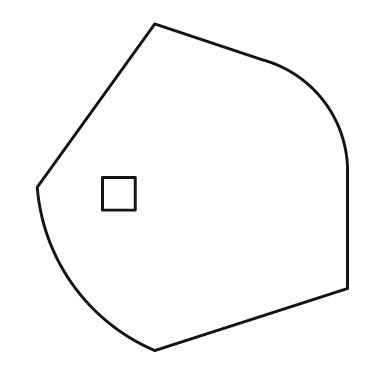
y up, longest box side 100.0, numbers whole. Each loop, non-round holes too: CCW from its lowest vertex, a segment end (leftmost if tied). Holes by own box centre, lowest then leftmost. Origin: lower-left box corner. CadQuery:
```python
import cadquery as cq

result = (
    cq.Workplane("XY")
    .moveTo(36.0, 0.0)
    .lineTo(95.0, 19.0)
    .lineTo(95.0, 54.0)
    .threePointArc((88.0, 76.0), (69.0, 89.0))
    .lineTo(36.0, 100.0)
    .lineTo(0.0, 50.0)
    .threePointArc((11.0, 20.0), (36.0, 0.0))
    .close()
    .moveTo(20.0, 43.0)
    .lineTo(30.0, 43.0)
    .lineTo(30.0, 53.0)
    .lineTo(20.0, 53.0)
    .close()
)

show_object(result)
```